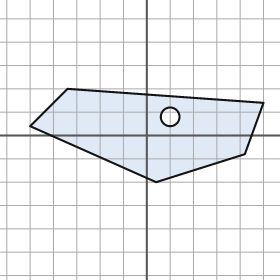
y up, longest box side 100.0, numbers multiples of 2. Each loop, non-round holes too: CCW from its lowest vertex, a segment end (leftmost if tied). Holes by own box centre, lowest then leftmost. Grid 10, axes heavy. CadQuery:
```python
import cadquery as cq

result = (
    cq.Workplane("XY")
    .moveTo(4.0, -20.0)
    .lineTo(42.0, -8.0)
    .lineTo(50.0, 14.0)
    .lineTo(-34.0, 20.0)
    .lineTo(-50.0, 4.0)
    .close()
    .moveTo(10.0, 8.0)
    .circle(4.0)
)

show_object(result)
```